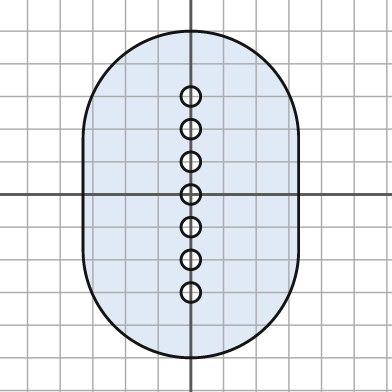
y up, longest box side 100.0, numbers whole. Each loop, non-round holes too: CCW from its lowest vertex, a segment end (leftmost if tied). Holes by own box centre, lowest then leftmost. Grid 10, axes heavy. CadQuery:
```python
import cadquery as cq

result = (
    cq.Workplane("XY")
    .moveTo(-33.0, -17.0)
    .threePointArc((0.0, -50.0), (33.0, -17.0))
    .lineTo(33.0, 17.0)
    .threePointArc((0.0, 50.0), (-33.0, 17.0))
    .close()
    .moveTo(0.0, -30.0)
    .circle(3.0)
    .moveTo(0.0, -20.0)
    .circle(3.0)
    .moveTo(0.0, -10.0)
    .circle(3.0)
    .moveTo(0.0, 0.0)
    .circle(3.0)
    .moveTo(0.0, 10.0)
    .circle(3.0)
    .moveTo(0.0, 20.0)
    .circle(3.0)
    .moveTo(0.0, 30.0)
    .circle(3.0)
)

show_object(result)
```